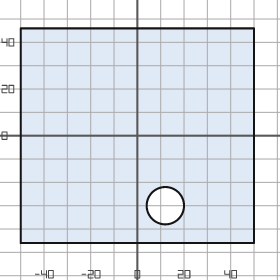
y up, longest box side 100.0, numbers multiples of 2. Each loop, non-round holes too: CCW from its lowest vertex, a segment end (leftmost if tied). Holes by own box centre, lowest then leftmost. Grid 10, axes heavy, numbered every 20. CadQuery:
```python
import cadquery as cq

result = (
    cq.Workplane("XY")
    .moveTo(-50.0, -46.0)
    .lineTo(50.0, -46.0)
    .lineTo(50.0, 46.0)
    .lineTo(-50.0, 46.0)
    .close()
    .moveTo(12.0, -30.0)
    .circle(8.0)
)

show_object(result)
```